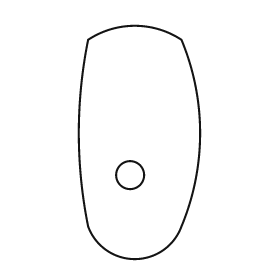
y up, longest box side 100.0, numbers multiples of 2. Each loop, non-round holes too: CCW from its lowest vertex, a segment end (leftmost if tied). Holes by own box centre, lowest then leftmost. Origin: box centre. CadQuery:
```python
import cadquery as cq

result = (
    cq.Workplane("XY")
    .moveTo(-22.0, -36.0)
    .threePointArc((-2.0, -50.0), (18.0, -36.0))
    .threePointArc((26.0, 4.0), (18.0, 44.0))
    .threePointArc((-2.0, 50.0), (-22.0, 44.0))
    .threePointArc((-26.0, 4.0), (-22.0, -36.0))
    .close()
    .moveTo(-4.0, -14.0)
    .circle(6.0)
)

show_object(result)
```